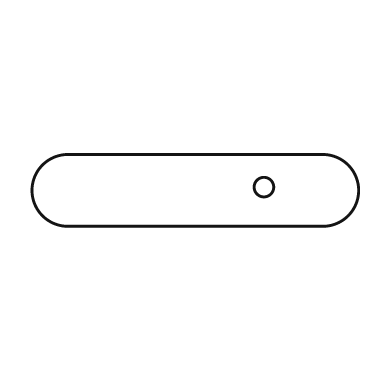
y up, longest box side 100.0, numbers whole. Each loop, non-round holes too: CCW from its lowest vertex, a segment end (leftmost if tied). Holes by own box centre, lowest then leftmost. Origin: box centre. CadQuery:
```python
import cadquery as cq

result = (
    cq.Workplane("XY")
    .moveTo(-39.0, -11.0)
    .lineTo(39.0, -11.0)
    .threePointArc((50.0, 0.0), (39.0, 11.0))
    .lineTo(-39.0, 11.0)
    .threePointArc((-50.0, 0.0), (-39.0, -11.0))
    .close()
    .moveTo(21.0, 1.0)
    .circle(3.0)
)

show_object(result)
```